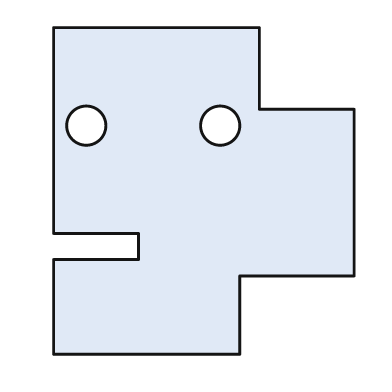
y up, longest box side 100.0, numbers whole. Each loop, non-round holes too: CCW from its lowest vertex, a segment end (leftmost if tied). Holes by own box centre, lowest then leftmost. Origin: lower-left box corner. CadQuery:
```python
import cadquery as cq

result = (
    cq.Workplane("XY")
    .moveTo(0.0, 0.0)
    .lineTo(57.0, 0.0)
    .lineTo(57.0, 24.0)
    .lineTo(92.0, 24.0)
    .lineTo(92.0, 75.0)
    .lineTo(63.0, 75.0)
    .lineTo(63.0, 100.0)
    .lineTo(0.0, 100.0)
    .lineTo(0.0, 37.0)
    .lineTo(26.0, 37.0)
    .lineTo(26.0, 29.0)
    .lineTo(0.0, 29.0)
    .close()
    .moveTo(10.0, 70.0)
    .circle(6.0)
    .moveTo(51.0, 70.0)
    .circle(6.0)
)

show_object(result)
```